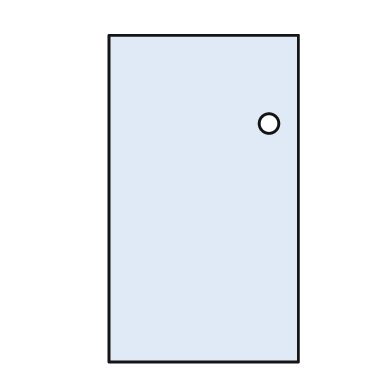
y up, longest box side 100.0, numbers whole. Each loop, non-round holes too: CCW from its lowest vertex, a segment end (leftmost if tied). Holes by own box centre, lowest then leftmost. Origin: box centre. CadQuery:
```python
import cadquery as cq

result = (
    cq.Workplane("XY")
    .moveTo(-29.0, -50.0)
    .lineTo(29.0, -50.0)
    .lineTo(29.0, 50.0)
    .lineTo(-29.0, 50.0)
    .close()
    .moveTo(20.0, 23.0)
    .circle(3.0)
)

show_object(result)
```